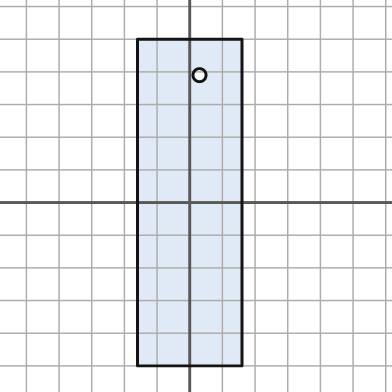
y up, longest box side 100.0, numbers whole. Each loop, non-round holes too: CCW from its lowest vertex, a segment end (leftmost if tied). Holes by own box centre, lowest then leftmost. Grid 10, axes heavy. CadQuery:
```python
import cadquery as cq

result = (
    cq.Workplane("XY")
    .moveTo(-16.0, -50.0)
    .lineTo(16.0, -50.0)
    .lineTo(16.0, 50.0)
    .lineTo(-16.0, 50.0)
    .close()
    .moveTo(3.0, 39.0)
    .circle(2.0)
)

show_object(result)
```